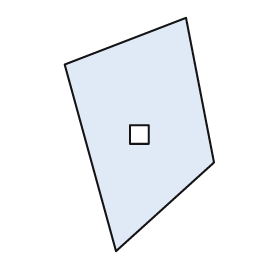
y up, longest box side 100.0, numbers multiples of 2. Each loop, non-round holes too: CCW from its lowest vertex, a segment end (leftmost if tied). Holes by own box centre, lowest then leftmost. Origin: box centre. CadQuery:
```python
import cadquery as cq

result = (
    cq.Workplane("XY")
    .moveTo(-10.0, -50.0)
    .lineTo(32.0, -12.0)
    .lineTo(20.0, 50.0)
    .lineTo(-32.0, 30.0)
    .close()
    .moveTo(-4.0, -4.0)
    .lineTo(4.0, -4.0)
    .lineTo(4.0, 4.0)
    .lineTo(-4.0, 4.0)
    .close()
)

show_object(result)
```